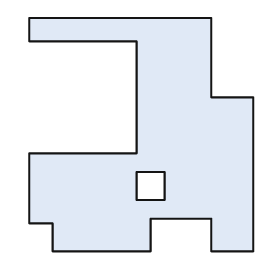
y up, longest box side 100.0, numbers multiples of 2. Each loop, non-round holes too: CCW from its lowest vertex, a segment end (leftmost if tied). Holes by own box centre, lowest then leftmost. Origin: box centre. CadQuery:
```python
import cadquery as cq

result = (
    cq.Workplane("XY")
    .moveTo(-38.0, -50.0)
    .lineTo(4.0, -50.0)
    .lineTo(4.0, -36.0)
    .lineTo(30.0, -36.0)
    .lineTo(30.0, -50.0)
    .lineTo(48.0, -50.0)
    .lineTo(48.0, 16.0)
    .lineTo(30.0, 16.0)
    .lineTo(30.0, 50.0)
    .lineTo(-48.0, 50.0)
    .lineTo(-48.0, 40.0)
    .lineTo(-2.0, 40.0)
    .lineTo(-2.0, -8.0)
    .lineTo(-48.0, -8.0)
    .lineTo(-48.0, -38.0)
    .lineTo(-38.0, -38.0)
    .close()
    .moveTo(-2.0, -28.0)
    .lineTo(10.0, -28.0)
    .lineTo(10.0, -16.0)
    .lineTo(-2.0, -16.0)
    .close()
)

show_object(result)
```